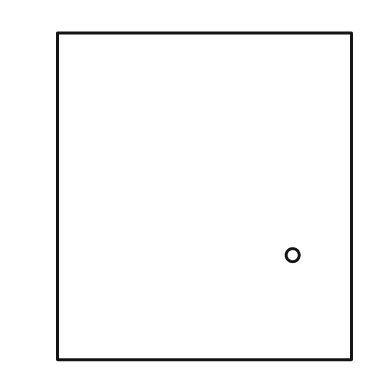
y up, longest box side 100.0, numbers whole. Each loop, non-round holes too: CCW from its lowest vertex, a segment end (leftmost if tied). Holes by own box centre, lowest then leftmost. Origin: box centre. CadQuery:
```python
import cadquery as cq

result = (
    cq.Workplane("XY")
    .moveTo(-45.0, -50.0)
    .lineTo(45.0, -50.0)
    .lineTo(45.0, 50.0)
    .lineTo(-45.0, 50.0)
    .close()
    .moveTo(27.0, -18.0)
    .circle(2.0)
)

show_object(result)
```